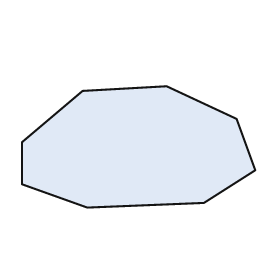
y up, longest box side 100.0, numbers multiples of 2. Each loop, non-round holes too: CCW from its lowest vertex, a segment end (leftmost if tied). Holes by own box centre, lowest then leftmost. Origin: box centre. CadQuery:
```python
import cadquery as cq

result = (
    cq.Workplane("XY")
    .moveTo(-22.0, -26.0)
    .lineTo(28.0, -24.0)
    .lineTo(50.0, -10.0)
    .lineTo(42.0, 12.0)
    .lineTo(12.0, 26.0)
    .lineTo(-24.0, 24.0)
    .lineTo(-50.0, 2.0)
    .lineTo(-50.0, -16.0)
    .close()
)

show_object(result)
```